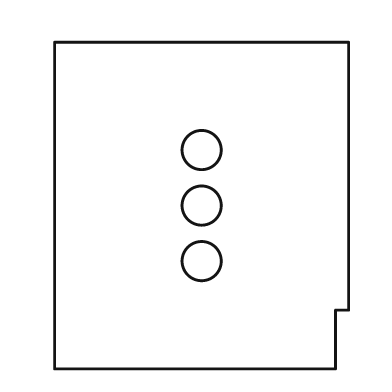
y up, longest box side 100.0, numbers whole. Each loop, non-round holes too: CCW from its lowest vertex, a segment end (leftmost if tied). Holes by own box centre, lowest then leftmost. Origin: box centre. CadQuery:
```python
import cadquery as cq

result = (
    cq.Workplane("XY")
    .moveTo(-45.0, -50.0)
    .lineTo(41.0, -50.0)
    .lineTo(41.0, -32.0)
    .lineTo(45.0, -32.0)
    .lineTo(45.0, 50.0)
    .lineTo(-45.0, 50.0)
    .close()
    .moveTo(0.0, -17.0)
    .circle(6.0)
    .moveTo(0.0, 0.0)
    .circle(6.0)
    .moveTo(0.0, 17.0)
    .circle(6.0)
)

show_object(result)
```